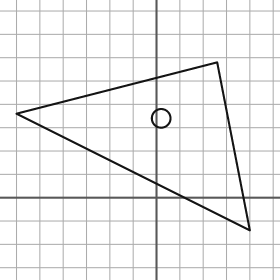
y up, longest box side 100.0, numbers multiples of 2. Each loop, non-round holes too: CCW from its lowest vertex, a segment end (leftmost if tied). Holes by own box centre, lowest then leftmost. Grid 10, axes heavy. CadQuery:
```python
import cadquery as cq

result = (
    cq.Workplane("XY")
    .moveTo(40.0, -14.0)
    .lineTo(26.0, 58.0)
    .lineTo(-60.0, 36.0)
    .close()
    .moveTo(2.0, 34.0)
    .circle(4.0)
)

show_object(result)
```